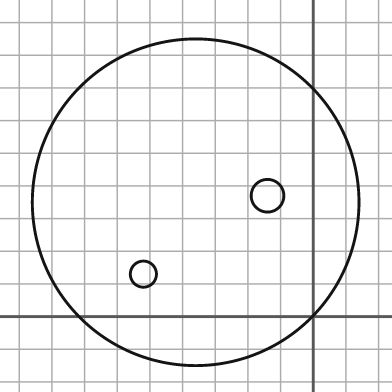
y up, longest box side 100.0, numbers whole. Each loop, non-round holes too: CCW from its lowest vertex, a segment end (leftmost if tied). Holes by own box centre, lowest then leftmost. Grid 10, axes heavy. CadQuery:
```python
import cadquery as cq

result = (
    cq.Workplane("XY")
    .moveTo(-36.0, 35.0)
    .circle(50.0)
    .moveTo(-52.0, 13.0)
    .circle(4.0)
    .moveTo(-14.0, 37.0)
    .circle(5.0)
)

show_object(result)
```